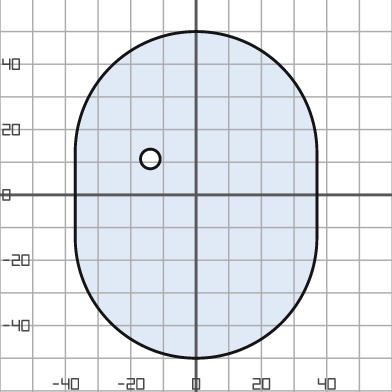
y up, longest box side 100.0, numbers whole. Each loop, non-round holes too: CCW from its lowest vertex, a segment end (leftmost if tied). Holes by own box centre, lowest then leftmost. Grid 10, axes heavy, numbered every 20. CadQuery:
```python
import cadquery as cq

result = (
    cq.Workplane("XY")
    .moveTo(-37.0, -13.0)
    .threePointArc((0.0, -50.0), (37.0, -13.0))
    .lineTo(37.0, 13.0)
    .threePointArc((0.0, 50.0), (-37.0, 13.0))
    .close()
    .moveTo(-14.0, 11.0)
    .circle(3.0)
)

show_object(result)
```